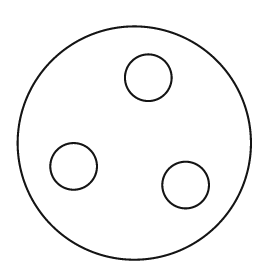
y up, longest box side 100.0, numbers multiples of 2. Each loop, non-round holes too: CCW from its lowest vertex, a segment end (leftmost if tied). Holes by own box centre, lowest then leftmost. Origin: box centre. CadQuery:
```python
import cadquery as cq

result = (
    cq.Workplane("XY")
    .moveTo(0.0, 0.0)
    .circle(50.0)
    .moveTo(22.0, -18.0)
    .circle(10.0)
    .moveTo(-26.0, -10.0)
    .circle(10.0)
    .moveTo(6.0, 28.0)
    .circle(10.0)
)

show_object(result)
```